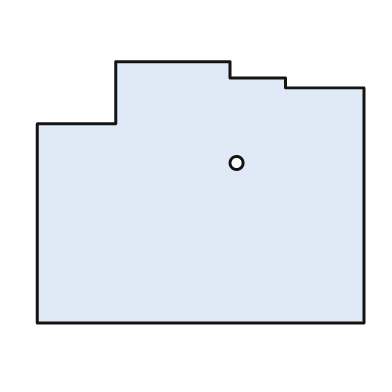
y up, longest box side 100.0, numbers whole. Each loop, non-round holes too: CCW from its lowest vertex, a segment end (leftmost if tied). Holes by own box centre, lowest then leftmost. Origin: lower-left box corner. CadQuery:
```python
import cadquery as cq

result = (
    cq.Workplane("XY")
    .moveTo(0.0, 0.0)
    .lineTo(100.0, 0.0)
    .lineTo(100.0, 72.0)
    .lineTo(76.0, 72.0)
    .lineTo(76.0, 75.0)
    .lineTo(59.0, 75.0)
    .lineTo(59.0, 80.0)
    .lineTo(24.0, 80.0)
    .lineTo(24.0, 61.0)
    .lineTo(0.0, 61.0)
    .close()
    .moveTo(61.0, 49.0)
    .circle(2.0)
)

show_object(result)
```